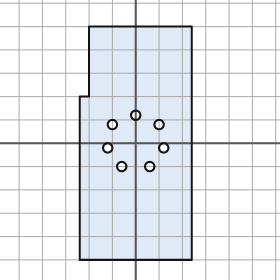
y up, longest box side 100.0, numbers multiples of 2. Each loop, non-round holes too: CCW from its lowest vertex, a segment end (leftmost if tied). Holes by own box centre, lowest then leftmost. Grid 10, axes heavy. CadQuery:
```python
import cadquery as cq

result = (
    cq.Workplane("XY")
    .moveTo(-24.0, -50.0)
    .lineTo(24.0, -50.0)
    .lineTo(24.0, 50.0)
    .lineTo(-20.0, 50.0)
    .lineTo(-20.0, 20.0)
    .lineTo(-24.0, 20.0)
    .close()
    .moveTo(-6.0, -10.0)
    .circle(2.0)
    .moveTo(6.0, -10.0)
    .circle(2.0)
    .moveTo(-12.0, -2.0)
    .circle(2.0)
    .moveTo(12.0, -2.0)
    .circle(2.0)
    .moveTo(-10.0, 8.0)
    .circle(2.0)
    .moveTo(10.0, 8.0)
    .circle(2.0)
    .moveTo(0.0, 12.0)
    .circle(2.0)
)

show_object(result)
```